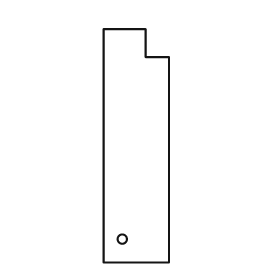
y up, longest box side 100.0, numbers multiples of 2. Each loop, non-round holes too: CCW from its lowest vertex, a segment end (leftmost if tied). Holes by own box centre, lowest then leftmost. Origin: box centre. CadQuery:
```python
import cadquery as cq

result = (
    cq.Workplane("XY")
    .moveTo(-14.0, -50.0)
    .lineTo(14.0, -50.0)
    .lineTo(14.0, 38.0)
    .lineTo(4.0, 38.0)
    .lineTo(4.0, 50.0)
    .lineTo(-14.0, 50.0)
    .close()
    .moveTo(-6.0, -40.0)
    .circle(2.0)
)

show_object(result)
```